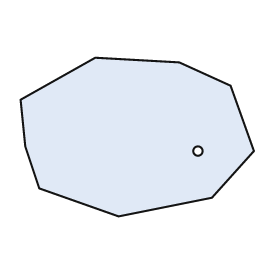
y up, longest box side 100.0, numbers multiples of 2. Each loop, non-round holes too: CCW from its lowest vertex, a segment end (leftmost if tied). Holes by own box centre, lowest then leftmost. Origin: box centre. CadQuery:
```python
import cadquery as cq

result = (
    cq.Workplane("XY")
    .moveTo(-8.0, -34.0)
    .lineTo(32.0, -26.0)
    .lineTo(50.0, -6.0)
    .lineTo(40.0, 22.0)
    .lineTo(18.0, 32.0)
    .lineTo(-18.0, 34.0)
    .lineTo(-50.0, 16.0)
    .lineTo(-48.0, -4.0)
    .lineTo(-42.0, -22.0)
    .close()
    .moveTo(26.0, -6.0)
    .circle(2.0)
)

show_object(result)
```